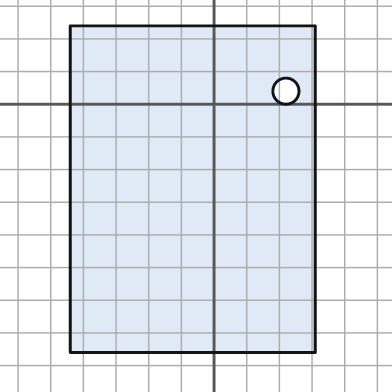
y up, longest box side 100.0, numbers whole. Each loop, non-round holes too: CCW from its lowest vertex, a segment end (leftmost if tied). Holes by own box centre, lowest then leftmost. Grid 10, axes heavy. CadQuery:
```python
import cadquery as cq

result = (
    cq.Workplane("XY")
    .moveTo(-44.0, -76.0)
    .lineTo(31.0, -76.0)
    .lineTo(31.0, 24.0)
    .lineTo(-44.0, 24.0)
    .close()
    .moveTo(22.0, 4.0)
    .circle(4.0)
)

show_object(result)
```